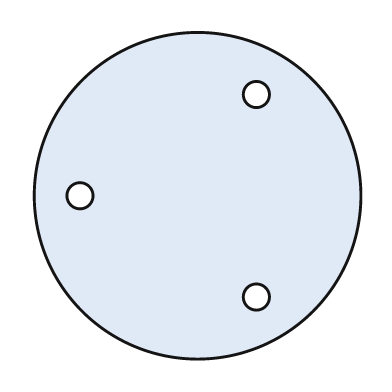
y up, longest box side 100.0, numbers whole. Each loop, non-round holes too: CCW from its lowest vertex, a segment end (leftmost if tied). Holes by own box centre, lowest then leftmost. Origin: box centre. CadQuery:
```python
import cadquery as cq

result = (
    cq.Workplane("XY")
    .moveTo(0.0, 0.0)
    .circle(50.0)
    .moveTo(18.0, -31.0)
    .circle(4.0)
    .moveTo(-36.0, 0.0)
    .circle(4.0)
    .moveTo(18.0, 31.0)
    .circle(4.0)
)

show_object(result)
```